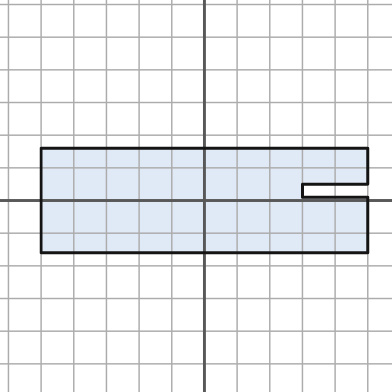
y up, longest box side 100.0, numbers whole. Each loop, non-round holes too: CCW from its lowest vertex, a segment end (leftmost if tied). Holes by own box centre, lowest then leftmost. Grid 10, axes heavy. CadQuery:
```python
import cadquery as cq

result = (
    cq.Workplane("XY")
    .moveTo(-50.0, -16.0)
    .lineTo(50.0, -16.0)
    .lineTo(50.0, 1.0)
    .lineTo(30.0, 1.0)
    .lineTo(30.0, 5.0)
    .lineTo(50.0, 5.0)
    .lineTo(50.0, 16.0)
    .lineTo(-50.0, 16.0)
    .close()
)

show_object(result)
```